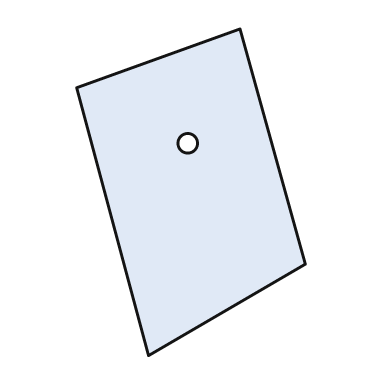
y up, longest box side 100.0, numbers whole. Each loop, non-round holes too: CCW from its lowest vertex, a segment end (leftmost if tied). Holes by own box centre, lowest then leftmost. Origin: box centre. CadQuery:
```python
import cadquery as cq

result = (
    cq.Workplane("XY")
    .moveTo(-13.0, -50.0)
    .lineTo(35.0, -22.0)
    .lineTo(15.0, 50.0)
    .lineTo(-35.0, 32.0)
    .close()
    .moveTo(-1.0, 15.0)
    .circle(3.0)
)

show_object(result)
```